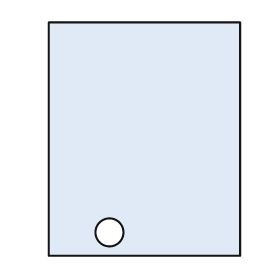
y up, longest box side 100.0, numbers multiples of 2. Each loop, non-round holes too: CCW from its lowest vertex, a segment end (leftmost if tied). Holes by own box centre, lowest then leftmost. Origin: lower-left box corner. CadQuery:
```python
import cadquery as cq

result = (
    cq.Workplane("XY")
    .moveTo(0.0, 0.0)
    .lineTo(82.0, 0.0)
    .lineTo(82.0, 100.0)
    .lineTo(0.0, 100.0)
    .close()
    .moveTo(26.0, 10.0)
    .circle(6.0)
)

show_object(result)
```